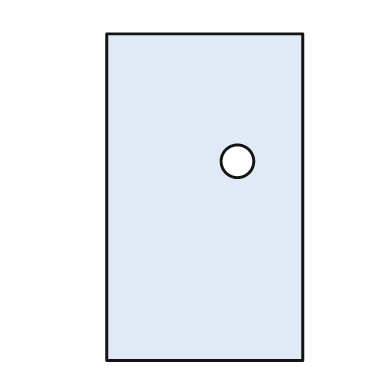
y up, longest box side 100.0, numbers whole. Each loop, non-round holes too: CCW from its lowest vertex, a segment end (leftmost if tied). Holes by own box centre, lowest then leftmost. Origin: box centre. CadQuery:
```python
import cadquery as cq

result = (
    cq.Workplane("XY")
    .moveTo(-30.0, -50.0)
    .lineTo(30.0, -50.0)
    .lineTo(30.0, 50.0)
    .lineTo(-30.0, 50.0)
    .close()
    .moveTo(10.0, 11.0)
    .circle(5.0)
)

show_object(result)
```